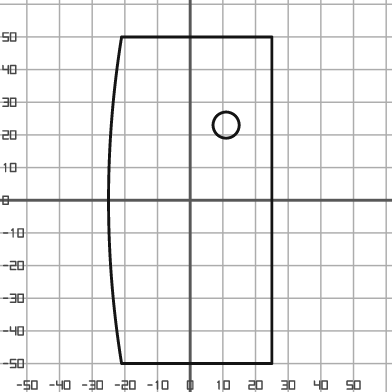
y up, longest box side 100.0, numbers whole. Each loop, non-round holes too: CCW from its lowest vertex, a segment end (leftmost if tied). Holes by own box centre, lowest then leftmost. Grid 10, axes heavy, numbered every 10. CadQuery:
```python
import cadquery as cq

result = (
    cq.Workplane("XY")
    .moveTo(-21.0, -50.0)
    .lineTo(25.0, -50.0)
    .lineTo(25.0, 50.0)
    .lineTo(-21.0, 50.0)
    .threePointArc((-25.0, 0.0), (-21.0, -50.0))
    .close()
    .moveTo(11.0, 23.0)
    .circle(4.0)
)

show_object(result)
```